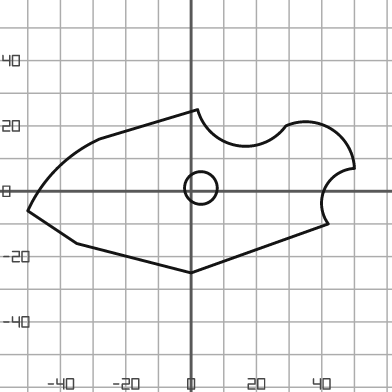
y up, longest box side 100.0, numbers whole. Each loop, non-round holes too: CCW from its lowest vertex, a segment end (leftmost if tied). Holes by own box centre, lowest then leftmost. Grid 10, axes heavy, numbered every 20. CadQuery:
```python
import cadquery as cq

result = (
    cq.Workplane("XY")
    .moveTo(0.0, -25.0)
    .lineTo(42.0, -10.0)
    .threePointArc((41.0, 1.0), (50.0, 7.0))
    .threePointArc((43.0, 19.0), (29.0, 20.0))
    .threePointArc((14.0, 14.0), (2.0, 25.0))
    .lineTo(-28.0, 16.0)
    .threePointArc((-41.0, 7.0), (-50.0, -6.0))
    .lineTo(-35.0, -16.0)
    .close()
    .moveTo(3.0, 1.0)
    .circle(5.0)
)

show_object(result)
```